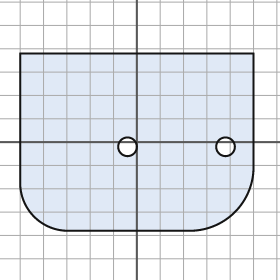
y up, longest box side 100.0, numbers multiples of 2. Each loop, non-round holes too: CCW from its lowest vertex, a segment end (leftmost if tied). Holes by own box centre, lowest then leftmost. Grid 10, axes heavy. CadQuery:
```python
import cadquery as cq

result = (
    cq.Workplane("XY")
    .moveTo(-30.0, -38.0)
    .lineTo(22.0, -38.0)
    .threePointArc((42.0, -30.0), (50.0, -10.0))
    .lineTo(50.0, 38.0)
    .lineTo(-50.0, 38.0)
    .lineTo(-50.0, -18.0)
    .threePointArc((-44.0, -32.0), (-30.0, -38.0))
    .close()
    .moveTo(-4.0, -2.0)
    .circle(4.0)
    .moveTo(38.0, -2.0)
    .circle(4.0)
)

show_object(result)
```